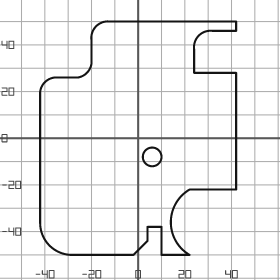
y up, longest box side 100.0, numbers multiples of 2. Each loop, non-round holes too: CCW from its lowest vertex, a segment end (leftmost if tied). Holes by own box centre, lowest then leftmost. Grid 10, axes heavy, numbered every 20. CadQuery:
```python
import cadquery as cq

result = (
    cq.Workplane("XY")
    .moveTo(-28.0, -50.0)
    .lineTo(-2.0, -50.0)
    .lineTo(4.0, -44.0)
    .lineTo(4.0, -38.0)
    .lineTo(10.0, -38.0)
    .lineTo(10.0, -50.0)
    .lineTo(22.0, -50.0)
    .threePointArc((14.0, -36.0), (22.0, -22.0))
    .lineTo(42.0, -22.0)
    .lineTo(42.0, 28.0)
    .lineTo(24.0, 28.0)
    .lineTo(24.0, 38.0)
    .threePointArc((26.0, 44.0), (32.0, 46.0))
    .lineTo(42.0, 46.0)
    .lineTo(42.0, 50.0)
    .lineTo(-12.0, 50.0)
    .threePointArc((-18.0, 48.0), (-20.0, 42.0))
    .lineTo(-20.0, 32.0)
    .threePointArc((-22.0, 28.0), (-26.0, 26.0))
    .lineTo(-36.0, 26.0)
    .threePointArc((-40.0, 24.0), (-42.0, 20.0))
    .lineTo(-42.0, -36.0)
    .threePointArc((-38.0, -46.0), (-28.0, -50.0))
    .close()
    .moveTo(6.0, -8.0)
    .circle(4.0)
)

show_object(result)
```